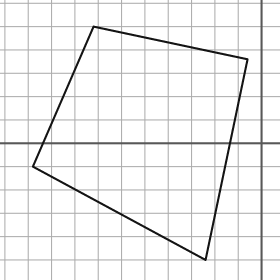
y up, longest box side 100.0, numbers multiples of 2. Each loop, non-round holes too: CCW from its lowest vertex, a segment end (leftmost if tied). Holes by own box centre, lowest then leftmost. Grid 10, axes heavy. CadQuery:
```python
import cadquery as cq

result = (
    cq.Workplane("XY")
    .moveTo(-24.0, -50.0)
    .lineTo(-6.0, 36.0)
    .lineTo(-72.0, 50.0)
    .lineTo(-98.0, -10.0)
    .close()
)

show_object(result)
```